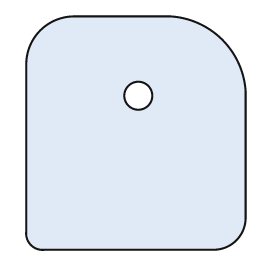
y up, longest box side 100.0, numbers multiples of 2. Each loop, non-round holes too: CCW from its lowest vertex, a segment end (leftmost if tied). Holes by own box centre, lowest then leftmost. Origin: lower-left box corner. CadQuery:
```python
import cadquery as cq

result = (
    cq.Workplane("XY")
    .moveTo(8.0, 0.0)
    .lineTo(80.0, 0.0)
    .threePointArc((90.0, 4.0), (94.0, 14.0))
    .lineTo(94.0, 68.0)
    .threePointArc((84.0, 90.0), (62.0, 100.0))
    .lineTo(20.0, 100.0)
    .threePointArc((6.0, 94.0), (0.0, 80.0))
    .lineTo(0.0, 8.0)
    .threePointArc((2.0, 2.0), (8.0, 0.0))
    .close()
    .moveTo(48.0, 66.0)
    .circle(6.0)
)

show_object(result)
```